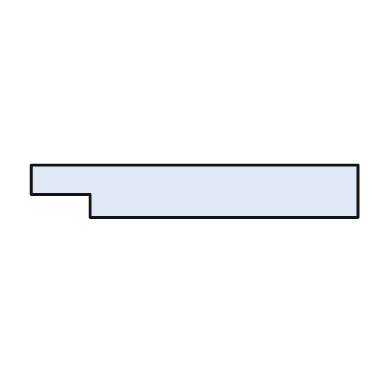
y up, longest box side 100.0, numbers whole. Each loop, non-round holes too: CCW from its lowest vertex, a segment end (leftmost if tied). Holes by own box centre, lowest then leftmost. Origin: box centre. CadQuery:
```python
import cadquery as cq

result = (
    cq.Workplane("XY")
    .moveTo(-32.0, -8.0)
    .lineTo(50.0, -8.0)
    .lineTo(50.0, 8.0)
    .lineTo(-50.0, 8.0)
    .lineTo(-50.0, -1.0)
    .lineTo(-32.0, -1.0)
    .close()
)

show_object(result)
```